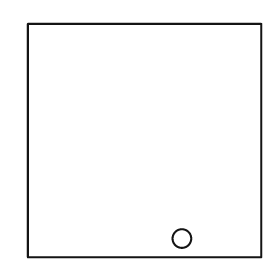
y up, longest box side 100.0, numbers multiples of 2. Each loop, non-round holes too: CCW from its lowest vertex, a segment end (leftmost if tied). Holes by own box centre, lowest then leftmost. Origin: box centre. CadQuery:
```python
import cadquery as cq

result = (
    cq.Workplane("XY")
    .moveTo(-50.0, -50.0)
    .lineTo(50.0, -50.0)
    .lineTo(50.0, 50.0)
    .lineTo(-50.0, 50.0)
    .close()
    .moveTo(16.0, -42.0)
    .circle(4.0)
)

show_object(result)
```